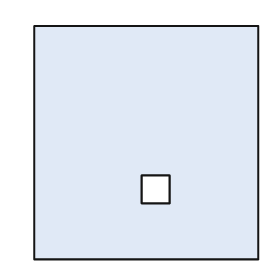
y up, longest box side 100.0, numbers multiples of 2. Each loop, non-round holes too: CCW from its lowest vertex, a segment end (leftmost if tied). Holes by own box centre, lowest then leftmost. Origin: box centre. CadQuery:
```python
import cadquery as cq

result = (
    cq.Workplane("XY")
    .moveTo(-48.0, -50.0)
    .lineTo(48.0, -50.0)
    .lineTo(48.0, 50.0)
    .lineTo(-48.0, 50.0)
    .close()
    .moveTo(-2.0, -26.0)
    .lineTo(10.0, -26.0)
    .lineTo(10.0, -14.0)
    .lineTo(-2.0, -14.0)
    .close()
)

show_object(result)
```